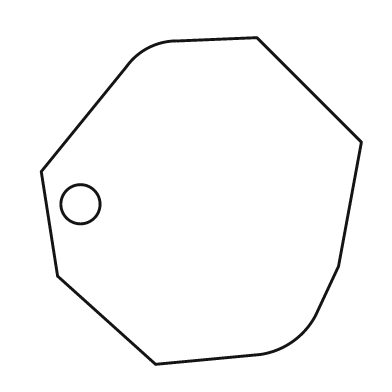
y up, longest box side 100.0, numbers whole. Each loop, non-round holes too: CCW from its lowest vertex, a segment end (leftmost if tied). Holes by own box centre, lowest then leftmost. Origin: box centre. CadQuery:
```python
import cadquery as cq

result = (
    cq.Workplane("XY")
    .moveTo(-14.0, -50.0)
    .lineTo(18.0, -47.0)
    .threePointArc((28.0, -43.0), (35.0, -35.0))
    .lineTo(42.0, -20.0)
    .lineTo(49.0, 18.0)
    .lineTo(17.0, 50.0)
    .lineTo(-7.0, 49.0)
    .threePointArc((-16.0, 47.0), (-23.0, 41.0))
    .lineTo(-49.0, 9.0)
    .lineTo(-44.0, -23.0)
    .close()
    .moveTo(-37.0, -1.0)
    .circle(6.0)
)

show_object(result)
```